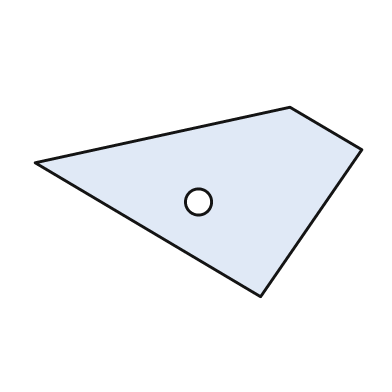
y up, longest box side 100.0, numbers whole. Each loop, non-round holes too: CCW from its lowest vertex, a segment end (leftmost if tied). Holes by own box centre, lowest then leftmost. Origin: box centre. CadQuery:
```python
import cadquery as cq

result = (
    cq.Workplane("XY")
    .moveTo(19.0, -29.0)
    .lineTo(50.0, 16.0)
    .lineTo(28.0, 29.0)
    .lineTo(-50.0, 12.0)
    .close()
    .moveTo(0.0, 0.0)
    .circle(4.0)
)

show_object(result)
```